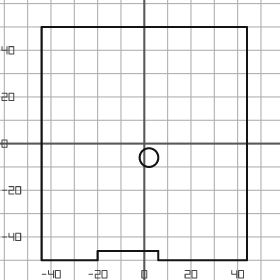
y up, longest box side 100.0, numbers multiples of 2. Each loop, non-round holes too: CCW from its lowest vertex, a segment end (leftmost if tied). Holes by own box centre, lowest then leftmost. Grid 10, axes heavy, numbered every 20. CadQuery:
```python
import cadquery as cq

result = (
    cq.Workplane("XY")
    .moveTo(-44.0, -50.0)
    .lineTo(-20.0, -50.0)
    .lineTo(-20.0, -46.0)
    .lineTo(6.0, -46.0)
    .lineTo(6.0, -50.0)
    .lineTo(44.0, -50.0)
    .lineTo(44.0, 50.0)
    .lineTo(-44.0, 50.0)
    .close()
    .moveTo(2.0, -6.0)
    .circle(4.0)
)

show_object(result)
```